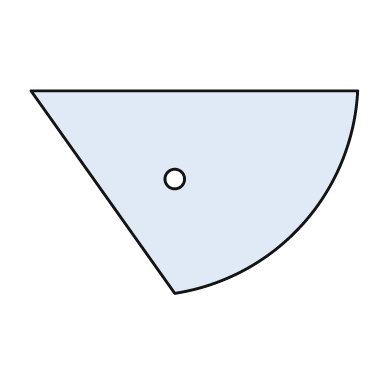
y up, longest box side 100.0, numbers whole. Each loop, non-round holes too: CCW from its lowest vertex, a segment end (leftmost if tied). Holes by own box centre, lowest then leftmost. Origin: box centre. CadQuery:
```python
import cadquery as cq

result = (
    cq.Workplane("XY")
    .moveTo(-6.0, -31.0)
    .threePointArc((33.0, -10.0), (50.0, 31.0))
    .lineTo(-50.0, 31.0)
    .close()
    .moveTo(-6.0, 4.0)
    .circle(3.0)
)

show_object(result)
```